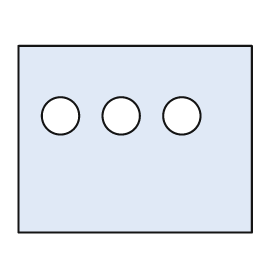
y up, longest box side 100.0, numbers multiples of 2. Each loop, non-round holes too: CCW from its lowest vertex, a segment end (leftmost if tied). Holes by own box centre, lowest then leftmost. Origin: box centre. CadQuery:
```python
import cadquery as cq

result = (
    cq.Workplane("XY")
    .moveTo(-50.0, -40.0)
    .lineTo(50.0, -40.0)
    .lineTo(50.0, 40.0)
    .lineTo(-50.0, 40.0)
    .close()
    .moveTo(-32.0, 10.0)
    .circle(8.0)
    .moveTo(-6.0, 10.0)
    .circle(8.0)
    .moveTo(20.0, 10.0)
    .circle(8.0)
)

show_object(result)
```